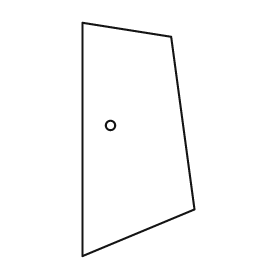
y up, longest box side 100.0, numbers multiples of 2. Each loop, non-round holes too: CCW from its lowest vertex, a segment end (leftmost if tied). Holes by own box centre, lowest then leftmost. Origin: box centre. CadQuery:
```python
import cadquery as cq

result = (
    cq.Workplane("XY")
    .moveTo(-24.0, -50.0)
    .lineTo(24.0, -30.0)
    .lineTo(14.0, 44.0)
    .lineTo(-24.0, 50.0)
    .close()
    .moveTo(-12.0, 6.0)
    .circle(2.0)
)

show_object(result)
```